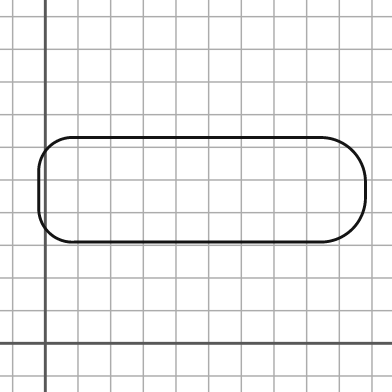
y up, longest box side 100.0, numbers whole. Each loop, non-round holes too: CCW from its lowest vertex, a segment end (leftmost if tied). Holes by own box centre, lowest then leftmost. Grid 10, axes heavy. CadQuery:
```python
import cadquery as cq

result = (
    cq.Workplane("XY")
    .moveTo(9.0, 31.0)
    .lineTo(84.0, 31.0)
    .threePointArc((94.0, 35.0), (98.0, 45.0))
    .lineTo(98.0, 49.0)
    .threePointArc((94.0, 59.0), (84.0, 63.0))
    .lineTo(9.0, 63.0)
    .threePointArc((1.0, 60.0), (-2.0, 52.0))
    .lineTo(-2.0, 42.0)
    .threePointArc((1.0, 34.0), (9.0, 31.0))
    .close()
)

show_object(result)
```